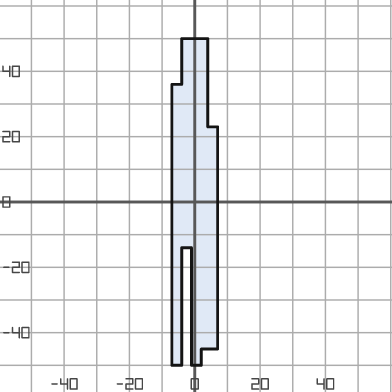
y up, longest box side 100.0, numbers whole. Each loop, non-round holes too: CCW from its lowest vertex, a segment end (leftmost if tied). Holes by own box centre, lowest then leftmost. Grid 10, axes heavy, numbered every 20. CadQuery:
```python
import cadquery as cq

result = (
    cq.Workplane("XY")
    .moveTo(-7.0, -50.0)
    .lineTo(-4.0, -50.0)
    .lineTo(-4.0, -14.0)
    .lineTo(-1.0, -14.0)
    .lineTo(-1.0, -50.0)
    .lineTo(2.0, -50.0)
    .lineTo(2.0, -45.0)
    .lineTo(7.0, -45.0)
    .lineTo(7.0, 23.0)
    .lineTo(4.0, 23.0)
    .lineTo(4.0, 50.0)
    .lineTo(-4.0, 50.0)
    .lineTo(-4.0, 36.0)
    .lineTo(-7.0, 36.0)
    .close()
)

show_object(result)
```